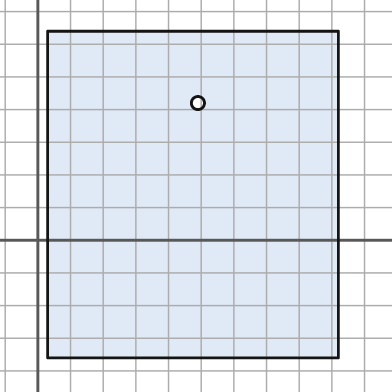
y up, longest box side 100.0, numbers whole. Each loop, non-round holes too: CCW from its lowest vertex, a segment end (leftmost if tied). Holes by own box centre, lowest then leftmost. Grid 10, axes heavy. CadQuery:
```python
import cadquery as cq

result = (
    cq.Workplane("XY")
    .moveTo(3.0, -36.0)
    .lineTo(92.0, -36.0)
    .lineTo(92.0, 64.0)
    .lineTo(3.0, 64.0)
    .close()
    .moveTo(49.0, 42.0)
    .circle(2.0)
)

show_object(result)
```